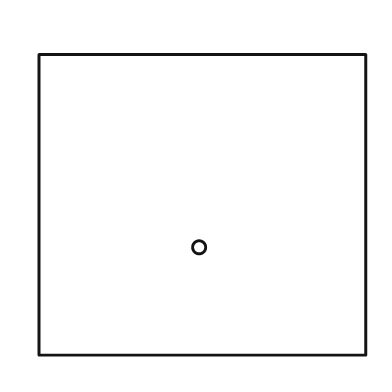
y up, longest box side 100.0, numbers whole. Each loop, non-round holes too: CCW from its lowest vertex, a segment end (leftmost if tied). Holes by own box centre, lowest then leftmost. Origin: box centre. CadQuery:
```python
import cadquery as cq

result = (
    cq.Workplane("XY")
    .moveTo(-50.0, -46.0)
    .lineTo(50.0, -46.0)
    .lineTo(50.0, 46.0)
    .lineTo(-50.0, 46.0)
    .close()
    .moveTo(-1.0, -13.0)
    .circle(2.0)
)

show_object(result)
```